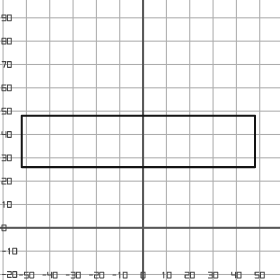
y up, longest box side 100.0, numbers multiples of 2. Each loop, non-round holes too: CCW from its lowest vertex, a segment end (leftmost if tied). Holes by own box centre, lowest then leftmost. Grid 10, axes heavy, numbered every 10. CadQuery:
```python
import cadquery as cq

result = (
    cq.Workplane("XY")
    .moveTo(-52.0, 26.0)
    .lineTo(48.0, 26.0)
    .lineTo(48.0, 48.0)
    .lineTo(-52.0, 48.0)
    .close()
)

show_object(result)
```